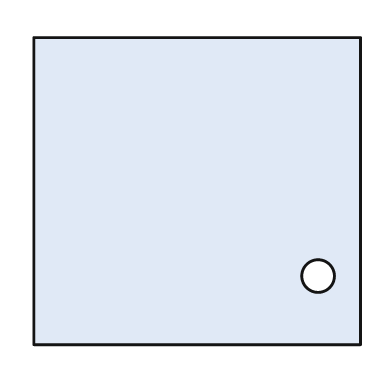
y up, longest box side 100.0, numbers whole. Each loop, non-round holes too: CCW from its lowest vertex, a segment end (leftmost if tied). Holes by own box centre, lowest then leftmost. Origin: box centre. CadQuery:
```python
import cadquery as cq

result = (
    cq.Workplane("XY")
    .moveTo(-50.0, -47.0)
    .lineTo(50.0, -47.0)
    .lineTo(50.0, 47.0)
    .lineTo(-50.0, 47.0)
    .close()
    .moveTo(37.0, -26.0)
    .circle(5.0)
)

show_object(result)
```